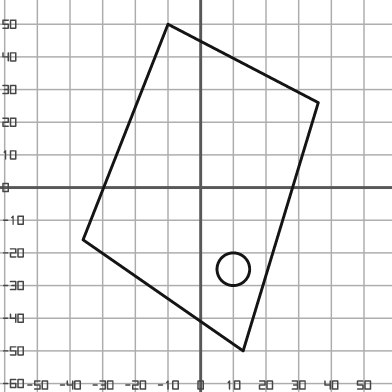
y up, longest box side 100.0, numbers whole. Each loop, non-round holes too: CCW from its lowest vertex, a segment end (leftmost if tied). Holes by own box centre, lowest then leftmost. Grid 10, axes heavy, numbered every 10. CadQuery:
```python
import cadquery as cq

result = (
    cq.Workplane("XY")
    .moveTo(13.0, -50.0)
    .lineTo(36.0, 26.0)
    .lineTo(-10.0, 50.0)
    .lineTo(-36.0, -16.0)
    .close()
    .moveTo(10.0, -25.0)
    .circle(5.0)
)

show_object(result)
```